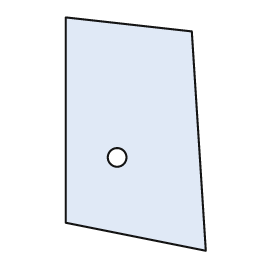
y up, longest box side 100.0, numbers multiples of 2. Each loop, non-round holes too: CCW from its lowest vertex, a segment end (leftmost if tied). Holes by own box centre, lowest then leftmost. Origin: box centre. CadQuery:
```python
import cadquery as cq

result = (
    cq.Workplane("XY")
    .moveTo(30.0, -50.0)
    .lineTo(24.0, 44.0)
    .lineTo(-30.0, 50.0)
    .lineTo(-30.0, -38.0)
    .close()
    .moveTo(-8.0, -10.0)
    .circle(4.0)
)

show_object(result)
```